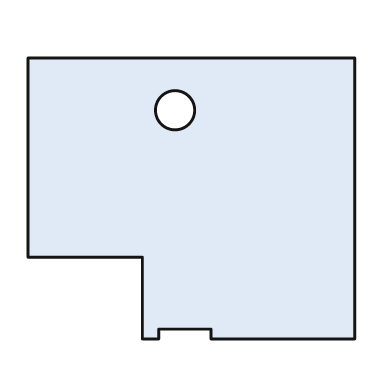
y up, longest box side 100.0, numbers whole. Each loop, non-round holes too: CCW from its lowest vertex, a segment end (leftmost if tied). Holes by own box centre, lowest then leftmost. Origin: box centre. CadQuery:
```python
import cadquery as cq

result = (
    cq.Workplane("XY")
    .moveTo(-15.0, -43.0)
    .lineTo(-10.0, -43.0)
    .lineTo(-10.0, -40.0)
    .lineTo(6.0, -40.0)
    .lineTo(6.0, -43.0)
    .lineTo(50.0, -43.0)
    .lineTo(50.0, 43.0)
    .lineTo(-50.0, 43.0)
    .lineTo(-50.0, -18.0)
    .lineTo(-15.0, -18.0)
    .close()
    .moveTo(-5.0, 27.0)
    .circle(6.0)
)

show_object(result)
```